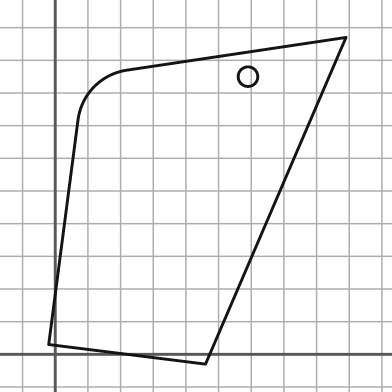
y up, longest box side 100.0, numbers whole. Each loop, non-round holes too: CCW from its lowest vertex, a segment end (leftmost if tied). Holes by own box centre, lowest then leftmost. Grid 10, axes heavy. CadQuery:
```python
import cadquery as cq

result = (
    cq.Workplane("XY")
    .moveTo(46.0, -3.0)
    .lineTo(89.0, 97.0)
    .lineTo(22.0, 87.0)
    .threePointArc((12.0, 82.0), (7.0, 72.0))
    .lineTo(-2.0, 3.0)
    .close()
    .moveTo(59.0, 85.0)
    .circle(3.0)
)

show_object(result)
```